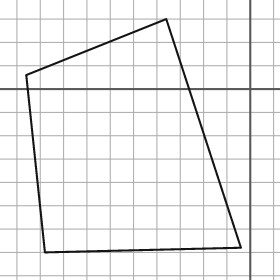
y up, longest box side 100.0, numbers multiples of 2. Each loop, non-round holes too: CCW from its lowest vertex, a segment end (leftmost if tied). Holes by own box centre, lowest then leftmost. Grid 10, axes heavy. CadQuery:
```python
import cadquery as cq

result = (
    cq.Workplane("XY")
    .moveTo(-88.0, -70.0)
    .lineTo(-4.0, -68.0)
    .lineTo(-36.0, 30.0)
    .lineTo(-96.0, 6.0)
    .close()
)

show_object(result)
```